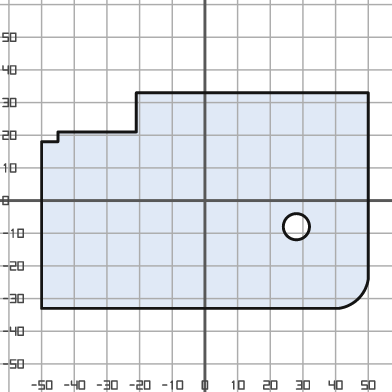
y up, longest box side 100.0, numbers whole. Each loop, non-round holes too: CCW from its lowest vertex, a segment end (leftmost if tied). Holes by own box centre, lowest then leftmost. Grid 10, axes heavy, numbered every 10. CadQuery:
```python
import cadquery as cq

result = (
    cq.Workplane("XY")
    .moveTo(-50.0, -33.0)
    .lineTo(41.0, -33.0)
    .threePointArc((47.0, -30.0), (50.0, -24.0))
    .lineTo(50.0, 33.0)
    .lineTo(-21.0, 33.0)
    .lineTo(-21.0, 21.0)
    .lineTo(-45.0, 21.0)
    .lineTo(-45.0, 18.0)
    .lineTo(-50.0, 18.0)
    .close()
    .moveTo(28.0, -8.0)
    .circle(4.0)
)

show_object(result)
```